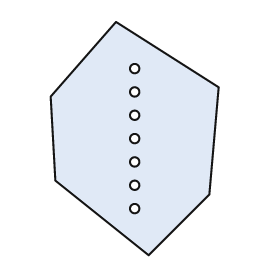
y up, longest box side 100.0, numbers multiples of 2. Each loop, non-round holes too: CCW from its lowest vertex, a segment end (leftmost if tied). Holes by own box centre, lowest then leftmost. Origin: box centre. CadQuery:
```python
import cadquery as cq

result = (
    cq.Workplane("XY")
    .moveTo(6.0, -50.0)
    .lineTo(32.0, -24.0)
    .lineTo(36.0, 22.0)
    .lineTo(-8.0, 50.0)
    .lineTo(-36.0, 18.0)
    .lineTo(-34.0, -18.0)
    .close()
    .moveTo(0.0, -30.0)
    .circle(2.0)
    .moveTo(0.0, -20.0)
    .circle(2.0)
    .moveTo(0.0, -10.0)
    .circle(2.0)
    .moveTo(0.0, 0.0)
    .circle(2.0)
    .moveTo(0.0, 10.0)
    .circle(2.0)
    .moveTo(0.0, 20.0)
    .circle(2.0)
    .moveTo(0.0, 30.0)
    .circle(2.0)
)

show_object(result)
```